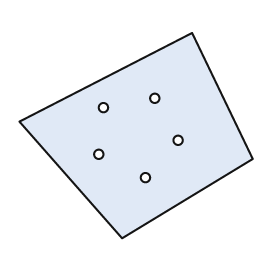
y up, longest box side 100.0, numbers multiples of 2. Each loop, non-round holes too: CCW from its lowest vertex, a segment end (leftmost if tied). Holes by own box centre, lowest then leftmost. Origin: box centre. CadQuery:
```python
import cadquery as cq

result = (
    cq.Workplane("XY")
    .moveTo(-6.0, -44.0)
    .lineTo(50.0, -10.0)
    .lineTo(24.0, 44.0)
    .lineTo(-50.0, 6.0)
    .close()
    .moveTo(4.0, -18.0)
    .circle(2.0)
    .moveTo(-16.0, -8.0)
    .circle(2.0)
    .moveTo(18.0, -2.0)
    .circle(2.0)
    .moveTo(-14.0, 12.0)
    .circle(2.0)
    .moveTo(8.0, 16.0)
    .circle(2.0)
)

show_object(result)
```